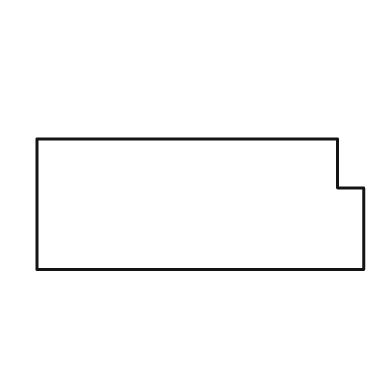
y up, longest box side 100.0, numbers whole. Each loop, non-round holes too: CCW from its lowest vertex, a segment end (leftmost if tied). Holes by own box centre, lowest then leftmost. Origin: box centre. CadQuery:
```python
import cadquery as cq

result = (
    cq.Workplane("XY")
    .moveTo(-50.0, -20.0)
    .lineTo(50.0, -20.0)
    .lineTo(50.0, 5.0)
    .lineTo(42.0, 5.0)
    .lineTo(42.0, 20.0)
    .lineTo(-50.0, 20.0)
    .close()
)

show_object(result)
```